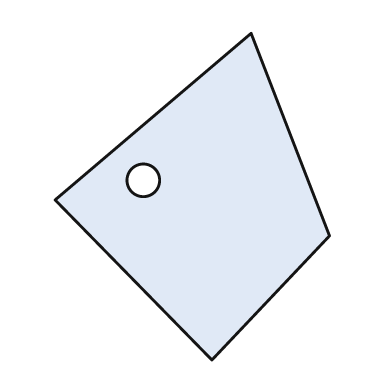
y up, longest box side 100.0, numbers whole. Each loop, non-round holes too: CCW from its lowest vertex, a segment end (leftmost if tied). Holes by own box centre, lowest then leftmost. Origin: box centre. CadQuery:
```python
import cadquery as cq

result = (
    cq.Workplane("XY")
    .moveTo(6.0, -50.0)
    .lineTo(42.0, -12.0)
    .lineTo(18.0, 50.0)
    .lineTo(-42.0, -1.0)
    .close()
    .moveTo(-15.0, 5.0)
    .circle(5.0)
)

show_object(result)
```